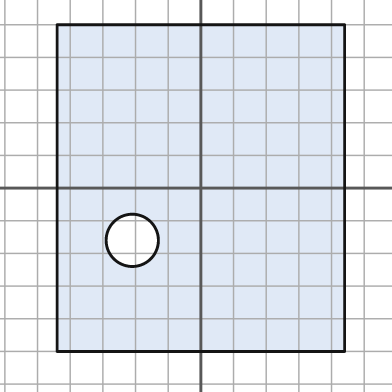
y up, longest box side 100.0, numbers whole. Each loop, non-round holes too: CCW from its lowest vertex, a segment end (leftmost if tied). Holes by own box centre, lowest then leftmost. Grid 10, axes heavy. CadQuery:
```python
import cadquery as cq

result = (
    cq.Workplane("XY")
    .moveTo(-44.0, -50.0)
    .lineTo(44.0, -50.0)
    .lineTo(44.0, 50.0)
    .lineTo(-44.0, 50.0)
    .close()
    .moveTo(-21.0, -16.0)
    .circle(8.0)
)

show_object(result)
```